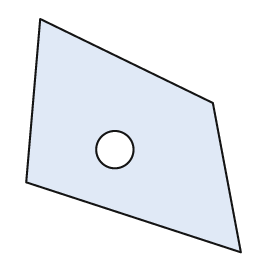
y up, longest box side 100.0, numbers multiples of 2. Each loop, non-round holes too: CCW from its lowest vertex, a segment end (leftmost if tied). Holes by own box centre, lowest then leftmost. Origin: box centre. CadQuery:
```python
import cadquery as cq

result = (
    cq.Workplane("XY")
    .moveTo(46.0, -50.0)
    .lineTo(34.0, 14.0)
    .lineTo(-40.0, 50.0)
    .lineTo(-46.0, -20.0)
    .close()
    .moveTo(-8.0, -6.0)
    .circle(8.0)
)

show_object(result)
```